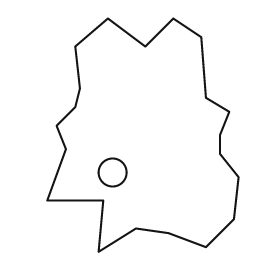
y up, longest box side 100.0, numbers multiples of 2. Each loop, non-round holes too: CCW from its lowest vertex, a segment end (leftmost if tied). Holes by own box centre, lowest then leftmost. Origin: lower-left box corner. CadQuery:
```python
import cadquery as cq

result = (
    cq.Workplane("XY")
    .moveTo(22.0, 0.0)
    .lineTo(38.0, 10.0)
    .lineTo(52.0, 8.0)
    .lineTo(68.0, 2.0)
    .lineTo(80.0, 14.0)
    .lineTo(82.0, 32.0)
    .lineTo(74.0, 42.0)
    .lineTo(74.0, 50.0)
    .lineTo(78.0, 60.0)
    .lineTo(68.0, 66.0)
    .lineTo(66.0, 92.0)
    .lineTo(54.0, 100.0)
    .lineTo(42.0, 88.0)
    .lineTo(26.0, 100.0)
    .lineTo(12.0, 88.0)
    .lineTo(14.0, 70.0)
    .lineTo(12.0, 62.0)
    .lineTo(4.0, 54.0)
    .lineTo(8.0, 44.0)
    .lineTo(0.0, 22.0)
    .lineTo(24.0, 22.0)
    .close()
    .moveTo(28.0, 34.0)
    .circle(6.0)
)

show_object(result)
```